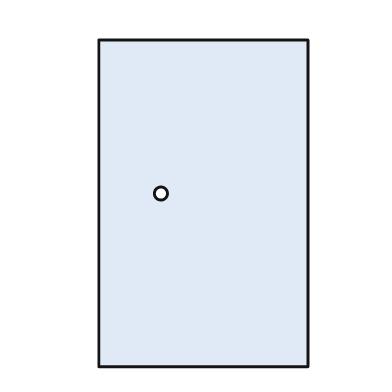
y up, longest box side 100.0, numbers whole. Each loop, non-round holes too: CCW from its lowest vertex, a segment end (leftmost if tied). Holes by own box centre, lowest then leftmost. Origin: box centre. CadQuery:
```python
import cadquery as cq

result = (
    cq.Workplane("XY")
    .moveTo(-32.0, -50.0)
    .lineTo(32.0, -50.0)
    .lineTo(32.0, 50.0)
    .lineTo(-32.0, 50.0)
    .close()
    .moveTo(-13.0, 3.0)
    .circle(2.0)
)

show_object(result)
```